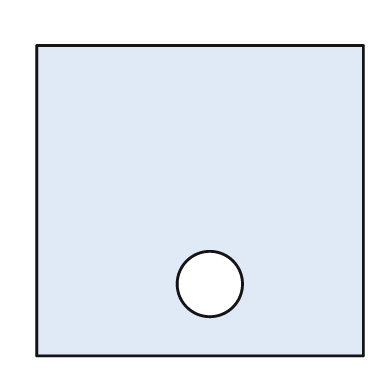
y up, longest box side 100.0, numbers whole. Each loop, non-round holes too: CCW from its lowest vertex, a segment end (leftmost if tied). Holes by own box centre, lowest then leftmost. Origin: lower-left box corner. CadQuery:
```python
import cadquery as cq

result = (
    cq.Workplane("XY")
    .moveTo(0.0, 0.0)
    .lineTo(100.0, 0.0)
    .lineTo(100.0, 95.0)
    .lineTo(0.0, 95.0)
    .close()
    .moveTo(53.0, 22.0)
    .circle(10.0)
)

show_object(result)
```